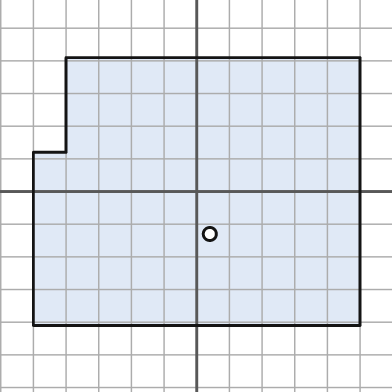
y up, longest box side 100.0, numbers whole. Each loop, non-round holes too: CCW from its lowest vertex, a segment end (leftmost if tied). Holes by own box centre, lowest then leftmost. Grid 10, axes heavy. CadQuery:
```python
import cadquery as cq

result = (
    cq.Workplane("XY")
    .moveTo(-50.0, -41.0)
    .lineTo(50.0, -41.0)
    .lineTo(50.0, 41.0)
    .lineTo(-40.0, 41.0)
    .lineTo(-40.0, 12.0)
    .lineTo(-50.0, 12.0)
    .close()
    .moveTo(4.0, -13.0)
    .circle(2.0)
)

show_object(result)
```